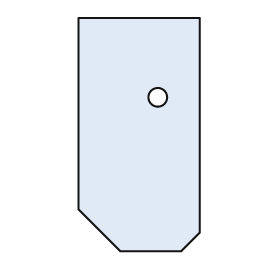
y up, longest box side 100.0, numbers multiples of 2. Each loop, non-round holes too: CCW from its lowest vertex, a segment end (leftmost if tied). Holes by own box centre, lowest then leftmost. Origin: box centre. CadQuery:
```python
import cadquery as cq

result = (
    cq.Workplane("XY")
    .moveTo(-8.0, -50.0)
    .lineTo(18.0, -50.0)
    .lineTo(26.0, -42.0)
    .lineTo(26.0, 50.0)
    .lineTo(-26.0, 50.0)
    .lineTo(-26.0, -32.0)
    .close()
    .moveTo(8.0, 16.0)
    .circle(4.0)
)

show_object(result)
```